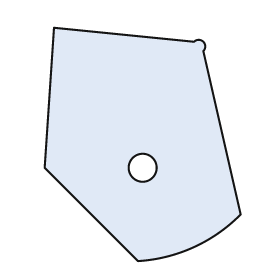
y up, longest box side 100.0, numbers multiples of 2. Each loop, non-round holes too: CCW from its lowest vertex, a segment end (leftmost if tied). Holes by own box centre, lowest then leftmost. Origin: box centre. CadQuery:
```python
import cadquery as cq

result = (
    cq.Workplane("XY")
    .moveTo(-2.0, -50.0)
    .threePointArc((22.0, -44.0), (42.0, -30.0))
    .lineTo(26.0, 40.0)
    .threePointArc((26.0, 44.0), (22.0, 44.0))
    .lineTo(-38.0, 50.0)
    .lineTo(-42.0, -10.0)
    .close()
    .moveTo(0.0, -10.0)
    .circle(6.0)
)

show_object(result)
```